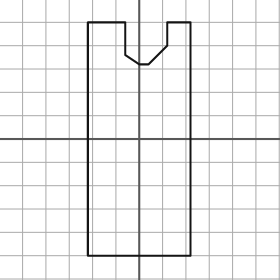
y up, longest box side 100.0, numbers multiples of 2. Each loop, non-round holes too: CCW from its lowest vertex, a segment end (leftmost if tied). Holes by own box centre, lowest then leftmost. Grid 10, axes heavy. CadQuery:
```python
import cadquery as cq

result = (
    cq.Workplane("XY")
    .moveTo(-22.0, -50.0)
    .lineTo(22.0, -50.0)
    .lineTo(22.0, 50.0)
    .lineTo(12.0, 50.0)
    .lineTo(12.0, 40.0)
    .lineTo(4.0, 32.0)
    .lineTo(0.0, 32.0)
    .lineTo(-6.0, 36.0)
    .lineTo(-6.0, 50.0)
    .lineTo(-22.0, 50.0)
    .close()
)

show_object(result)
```